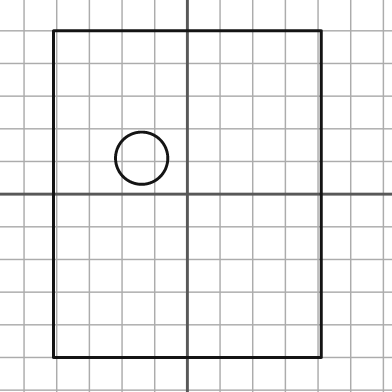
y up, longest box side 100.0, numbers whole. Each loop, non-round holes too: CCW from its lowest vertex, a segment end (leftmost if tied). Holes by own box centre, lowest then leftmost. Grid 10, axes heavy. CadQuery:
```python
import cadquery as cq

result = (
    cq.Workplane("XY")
    .moveTo(-41.0, -50.0)
    .lineTo(41.0, -50.0)
    .lineTo(41.0, 50.0)
    .lineTo(-41.0, 50.0)
    .close()
    .moveTo(-14.0, 11.0)
    .circle(8.0)
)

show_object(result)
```